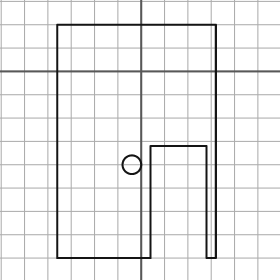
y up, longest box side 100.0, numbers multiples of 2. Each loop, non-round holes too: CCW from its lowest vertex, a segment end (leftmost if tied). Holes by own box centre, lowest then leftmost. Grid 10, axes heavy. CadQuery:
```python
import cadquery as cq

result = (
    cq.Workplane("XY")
    .moveTo(-36.0, -80.0)
    .lineTo(4.0, -80.0)
    .lineTo(4.0, -32.0)
    .lineTo(28.0, -32.0)
    .lineTo(28.0, -80.0)
    .lineTo(32.0, -80.0)
    .lineTo(32.0, 20.0)
    .lineTo(-36.0, 20.0)
    .close()
    .moveTo(-4.0, -40.0)
    .circle(4.0)
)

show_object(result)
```